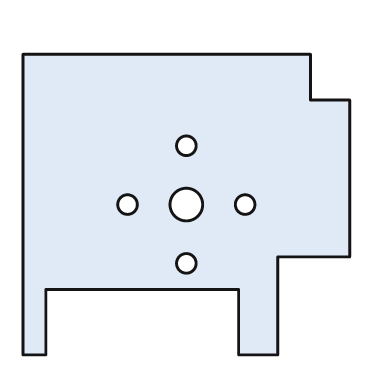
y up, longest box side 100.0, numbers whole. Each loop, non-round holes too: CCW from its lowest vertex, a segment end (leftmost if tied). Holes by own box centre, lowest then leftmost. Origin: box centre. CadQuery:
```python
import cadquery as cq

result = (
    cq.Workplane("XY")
    .moveTo(-50.0, -46.0)
    .lineTo(-43.0, -46.0)
    .lineTo(-43.0, -26.0)
    .lineTo(16.0, -26.0)
    .lineTo(16.0, -46.0)
    .lineTo(28.0, -46.0)
    .lineTo(28.0, -16.0)
    .lineTo(50.0, -16.0)
    .lineTo(50.0, 32.0)
    .lineTo(38.0, 32.0)
    .lineTo(38.0, 46.0)
    .lineTo(-50.0, 46.0)
    .close()
    .moveTo(0.0, -18.0)
    .circle(3.0)
    .moveTo(-18.0, 0.0)
    .circle(3.0)
    .moveTo(0.0, 0.0)
    .circle(5.0)
    .moveTo(18.0, 0.0)
    .circle(3.0)
    .moveTo(0.0, 18.0)
    .circle(3.0)
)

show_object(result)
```